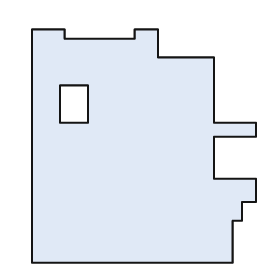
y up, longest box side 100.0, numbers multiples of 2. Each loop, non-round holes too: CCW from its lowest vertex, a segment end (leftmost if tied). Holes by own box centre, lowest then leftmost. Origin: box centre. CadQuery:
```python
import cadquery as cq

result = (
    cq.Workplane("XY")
    .moveTo(-48.0, -50.0)
    .lineTo(38.0, -50.0)
    .lineTo(38.0, -32.0)
    .lineTo(42.0, -32.0)
    .lineTo(42.0, -24.0)
    .lineTo(48.0, -24.0)
    .lineTo(48.0, -14.0)
    .lineTo(30.0, -14.0)
    .lineTo(30.0, 4.0)
    .lineTo(48.0, 4.0)
    .lineTo(48.0, 10.0)
    .lineTo(30.0, 10.0)
    .lineTo(30.0, 38.0)
    .lineTo(6.0, 38.0)
    .lineTo(6.0, 50.0)
    .lineTo(-4.0, 50.0)
    .lineTo(-4.0, 46.0)
    .lineTo(-34.0, 46.0)
    .lineTo(-34.0, 50.0)
    .lineTo(-48.0, 50.0)
    .close()
    .moveTo(-36.0, 10.0)
    .lineTo(-24.0, 10.0)
    .lineTo(-24.0, 26.0)
    .lineTo(-36.0, 26.0)
    .close()
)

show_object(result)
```